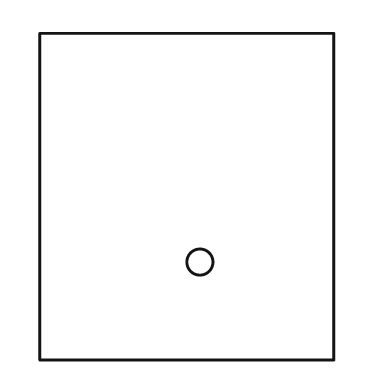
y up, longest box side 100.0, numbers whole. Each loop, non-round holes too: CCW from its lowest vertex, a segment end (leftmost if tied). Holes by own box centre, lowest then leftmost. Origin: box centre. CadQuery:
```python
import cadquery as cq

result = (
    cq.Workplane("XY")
    .moveTo(-45.0, -50.0)
    .lineTo(45.0, -50.0)
    .lineTo(45.0, 50.0)
    .lineTo(-45.0, 50.0)
    .close()
    .moveTo(4.0, -20.0)
    .circle(4.0)
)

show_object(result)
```